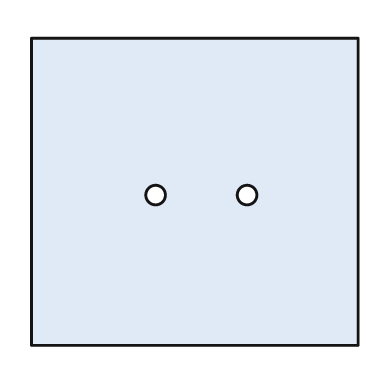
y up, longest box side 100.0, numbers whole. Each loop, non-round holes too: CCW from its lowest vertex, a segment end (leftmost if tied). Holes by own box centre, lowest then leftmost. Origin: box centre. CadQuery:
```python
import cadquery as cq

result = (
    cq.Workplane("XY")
    .moveTo(-50.0, -47.0)
    .lineTo(50.0, -47.0)
    .lineTo(50.0, 47.0)
    .lineTo(-50.0, 47.0)
    .close()
    .moveTo(-12.0, -1.0)
    .circle(3.0)
    .moveTo(16.0, -1.0)
    .circle(3.0)
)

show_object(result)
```